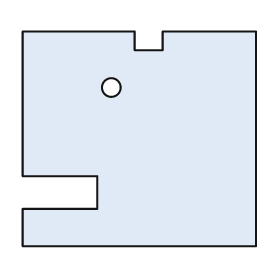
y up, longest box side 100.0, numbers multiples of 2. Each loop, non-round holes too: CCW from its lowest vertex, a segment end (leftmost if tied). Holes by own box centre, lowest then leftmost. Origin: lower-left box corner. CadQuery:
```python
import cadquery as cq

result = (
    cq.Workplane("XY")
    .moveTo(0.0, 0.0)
    .lineTo(100.0, 0.0)
    .lineTo(100.0, 92.0)
    .lineTo(60.0, 92.0)
    .lineTo(60.0, 84.0)
    .lineTo(48.0, 84.0)
    .lineTo(48.0, 92.0)
    .lineTo(0.0, 92.0)
    .lineTo(0.0, 30.0)
    .lineTo(32.0, 30.0)
    .lineTo(32.0, 16.0)
    .lineTo(0.0, 16.0)
    .close()
    .moveTo(38.0, 68.0)
    .circle(4.0)
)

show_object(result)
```